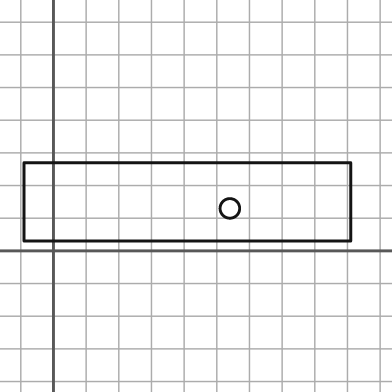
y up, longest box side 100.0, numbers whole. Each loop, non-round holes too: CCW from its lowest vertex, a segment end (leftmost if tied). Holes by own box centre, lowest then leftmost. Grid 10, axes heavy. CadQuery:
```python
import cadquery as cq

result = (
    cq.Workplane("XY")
    .moveTo(-9.0, 3.0)
    .lineTo(91.0, 3.0)
    .lineTo(91.0, 27.0)
    .lineTo(-9.0, 27.0)
    .close()
    .moveTo(54.0, 13.0)
    .circle(3.0)
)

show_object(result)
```